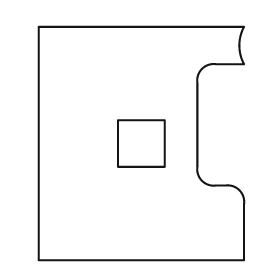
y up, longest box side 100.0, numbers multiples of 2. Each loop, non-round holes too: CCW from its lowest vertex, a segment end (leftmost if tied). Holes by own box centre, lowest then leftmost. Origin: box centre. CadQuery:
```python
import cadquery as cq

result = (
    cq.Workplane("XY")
    .moveTo(-44.0, -50.0)
    .lineTo(44.0, -50.0)
    .lineTo(44.0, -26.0)
    .threePointArc((42.0, -20.0), (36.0, -18.0))
    .lineTo(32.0, -18.0)
    .threePointArc((26.0, -16.0), (24.0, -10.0))
    .lineTo(24.0, 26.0)
    .threePointArc((26.0, 32.0), (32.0, 34.0))
    .lineTo(44.0, 34.0)
    .threePointArc((42.0, 42.0), (44.0, 50.0))
    .lineTo(-44.0, 50.0)
    .close()
    .moveTo(-10.0, -10.0)
    .lineTo(10.0, -10.0)
    .lineTo(10.0, 10.0)
    .lineTo(-10.0, 10.0)
    .close()
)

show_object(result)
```